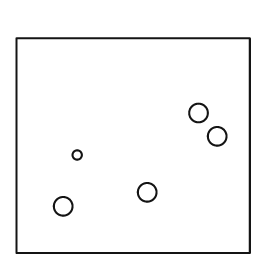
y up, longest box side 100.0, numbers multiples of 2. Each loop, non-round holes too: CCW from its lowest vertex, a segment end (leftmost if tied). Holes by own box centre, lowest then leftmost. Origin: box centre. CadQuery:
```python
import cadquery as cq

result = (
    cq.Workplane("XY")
    .moveTo(-50.0, -46.0)
    .lineTo(50.0, -46.0)
    .lineTo(50.0, 46.0)
    .lineTo(-50.0, 46.0)
    .close()
    .moveTo(-30.0, -26.0)
    .circle(4.0)
    .moveTo(6.0, -20.0)
    .circle(4.0)
    .moveTo(-24.0, -4.0)
    .circle(2.0)
    .moveTo(36.0, 4.0)
    .circle(4.0)
    .moveTo(28.0, 14.0)
    .circle(4.0)
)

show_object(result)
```